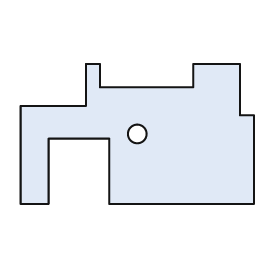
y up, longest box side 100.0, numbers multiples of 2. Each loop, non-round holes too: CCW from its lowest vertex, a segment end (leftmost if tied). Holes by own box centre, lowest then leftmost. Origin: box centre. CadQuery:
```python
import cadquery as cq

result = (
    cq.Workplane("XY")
    .moveTo(-50.0, -30.0)
    .lineTo(-38.0, -30.0)
    .lineTo(-38.0, -2.0)
    .lineTo(-12.0, -2.0)
    .lineTo(-12.0, -30.0)
    .lineTo(50.0, -30.0)
    .lineTo(50.0, 8.0)
    .lineTo(44.0, 8.0)
    .lineTo(44.0, 30.0)
    .lineTo(24.0, 30.0)
    .lineTo(24.0, 20.0)
    .lineTo(-16.0, 20.0)
    .lineTo(-16.0, 30.0)
    .lineTo(-22.0, 30.0)
    .lineTo(-22.0, 12.0)
    .lineTo(-50.0, 12.0)
    .close()
    .moveTo(0.0, 0.0)
    .circle(4.0)
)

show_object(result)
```